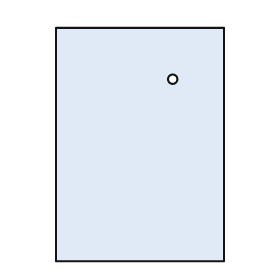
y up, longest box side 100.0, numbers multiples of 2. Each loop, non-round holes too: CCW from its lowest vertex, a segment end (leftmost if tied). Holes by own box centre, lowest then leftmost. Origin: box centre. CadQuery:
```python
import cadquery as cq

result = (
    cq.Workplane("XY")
    .moveTo(-36.0, -50.0)
    .lineTo(36.0, -50.0)
    .lineTo(36.0, 50.0)
    .lineTo(-36.0, 50.0)
    .close()
    .moveTo(14.0, 28.0)
    .circle(2.0)
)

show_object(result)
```